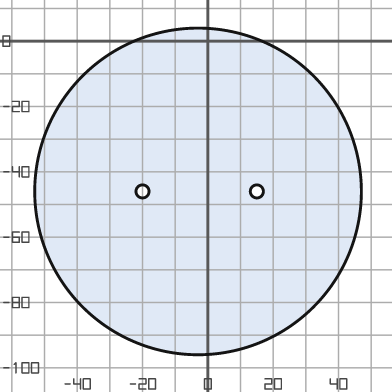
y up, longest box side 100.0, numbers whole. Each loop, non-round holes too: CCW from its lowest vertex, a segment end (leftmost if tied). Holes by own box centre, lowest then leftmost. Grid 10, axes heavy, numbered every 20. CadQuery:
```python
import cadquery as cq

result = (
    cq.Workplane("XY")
    .moveTo(-3.0, -46.0)
    .circle(50.0)
    .moveTo(-20.0, -46.0)
    .circle(2.0)
    .moveTo(15.0, -46.0)
    .circle(2.0)
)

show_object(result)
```